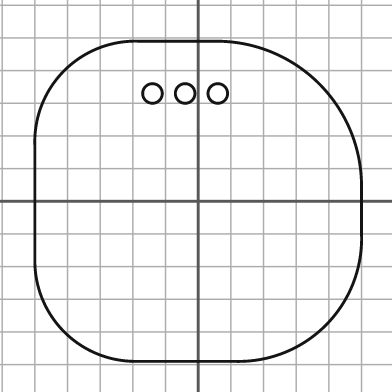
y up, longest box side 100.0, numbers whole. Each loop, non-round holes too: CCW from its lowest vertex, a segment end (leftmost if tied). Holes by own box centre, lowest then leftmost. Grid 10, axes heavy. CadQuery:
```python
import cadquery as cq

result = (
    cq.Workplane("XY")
    .moveTo(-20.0, -49.0)
    .lineTo(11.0, -49.0)
    .threePointArc((39.0, -38.0), (50.0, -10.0))
    .lineTo(50.0, 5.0)
    .threePointArc((37.0, 36.0), (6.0, 49.0))
    .lineTo(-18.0, 49.0)
    .threePointArc((-41.0, 40.0), (-50.0, 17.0))
    .lineTo(-50.0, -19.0)
    .threePointArc((-41.0, -40.0), (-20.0, -49.0))
    .close()
    .moveTo(-14.0, 33.0)
    .circle(3.0)
    .moveTo(-4.0, 33.0)
    .circle(3.0)
    .moveTo(6.0, 33.0)
    .circle(3.0)
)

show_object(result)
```